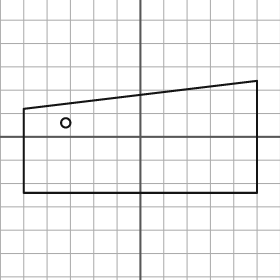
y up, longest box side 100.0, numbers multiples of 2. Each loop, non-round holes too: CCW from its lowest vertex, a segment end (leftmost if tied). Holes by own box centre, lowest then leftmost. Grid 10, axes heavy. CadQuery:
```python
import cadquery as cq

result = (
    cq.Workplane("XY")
    .moveTo(-50.0, -24.0)
    .lineTo(50.0, -24.0)
    .lineTo(50.0, 24.0)
    .lineTo(-50.0, 12.0)
    .close()
    .moveTo(-32.0, 6.0)
    .circle(2.0)
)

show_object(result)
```